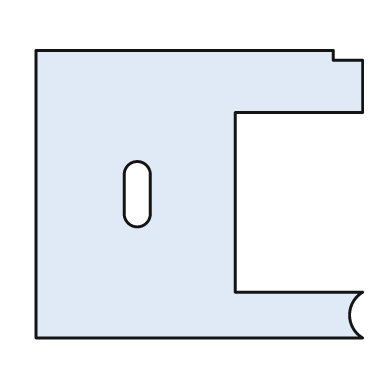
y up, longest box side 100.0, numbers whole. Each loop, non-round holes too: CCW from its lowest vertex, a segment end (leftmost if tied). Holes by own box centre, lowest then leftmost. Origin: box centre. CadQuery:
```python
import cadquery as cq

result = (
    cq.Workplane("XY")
    .moveTo(-50.0, -44.0)
    .lineTo(50.0, -44.0)
    .threePointArc((46.0, -37.0), (50.0, -30.0))
    .lineTo(11.0, -30.0)
    .lineTo(11.0, 25.0)
    .lineTo(50.0, 25.0)
    .lineTo(50.0, 41.0)
    .lineTo(41.0, 41.0)
    .lineTo(41.0, 44.0)
    .lineTo(-50.0, 44.0)
    .close()
    .moveTo(-23.0, -6.0)
    .threePointArc((-19.0, -10.0), (-15.0, -6.0))
    .lineTo(-15.0, 6.0)
    .threePointArc((-19.0, 10.0), (-23.0, 6.0))
    .close()
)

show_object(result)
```